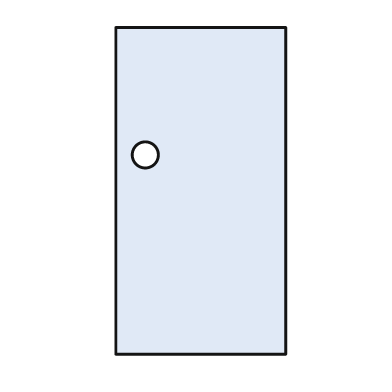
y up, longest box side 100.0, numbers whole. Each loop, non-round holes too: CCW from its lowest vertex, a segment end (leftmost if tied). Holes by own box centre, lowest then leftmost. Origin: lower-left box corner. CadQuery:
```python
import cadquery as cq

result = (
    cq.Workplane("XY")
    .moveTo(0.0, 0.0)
    .lineTo(52.0, 0.0)
    .lineTo(52.0, 100.0)
    .lineTo(0.0, 100.0)
    .close()
    .moveTo(9.0, 61.0)
    .circle(4.0)
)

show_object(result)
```